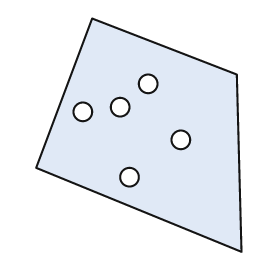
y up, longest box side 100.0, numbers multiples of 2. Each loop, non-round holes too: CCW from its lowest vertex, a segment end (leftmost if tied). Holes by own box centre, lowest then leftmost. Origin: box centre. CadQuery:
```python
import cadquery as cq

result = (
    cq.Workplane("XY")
    .moveTo(44.0, -50.0)
    .lineTo(42.0, 26.0)
    .lineTo(-20.0, 50.0)
    .lineTo(-44.0, -14.0)
    .close()
    .moveTo(-4.0, -18.0)
    .circle(4.0)
    .moveTo(18.0, -2.0)
    .circle(4.0)
    .moveTo(-24.0, 10.0)
    .circle(4.0)
    .moveTo(-8.0, 12.0)
    .circle(4.0)
    .moveTo(4.0, 22.0)
    .circle(4.0)
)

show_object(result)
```